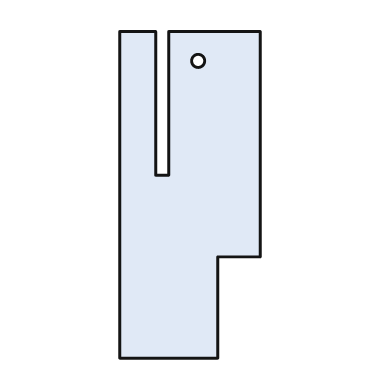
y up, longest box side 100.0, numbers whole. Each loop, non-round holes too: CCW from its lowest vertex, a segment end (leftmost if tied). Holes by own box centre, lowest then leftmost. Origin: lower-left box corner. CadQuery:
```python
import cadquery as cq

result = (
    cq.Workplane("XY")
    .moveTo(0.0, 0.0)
    .lineTo(30.0, 0.0)
    .lineTo(30.0, 31.0)
    .lineTo(43.0, 31.0)
    .lineTo(43.0, 100.0)
    .lineTo(15.0, 100.0)
    .lineTo(15.0, 56.0)
    .lineTo(11.0, 56.0)
    .lineTo(11.0, 100.0)
    .lineTo(0.0, 100.0)
    .close()
    .moveTo(24.0, 91.0)
    .circle(2.0)
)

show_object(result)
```